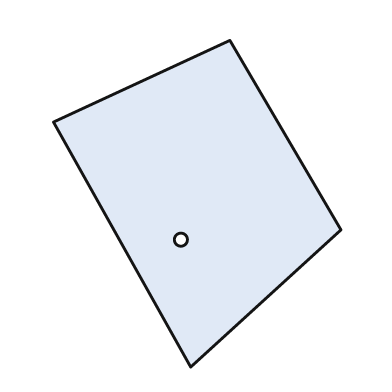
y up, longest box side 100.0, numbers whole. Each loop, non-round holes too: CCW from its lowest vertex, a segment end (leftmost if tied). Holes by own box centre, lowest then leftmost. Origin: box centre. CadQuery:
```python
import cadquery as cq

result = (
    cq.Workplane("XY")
    .moveTo(-2.0, -50.0)
    .lineTo(44.0, -8.0)
    .lineTo(10.0, 50.0)
    .lineTo(-44.0, 25.0)
    .close()
    .moveTo(-5.0, -11.0)
    .circle(2.0)
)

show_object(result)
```